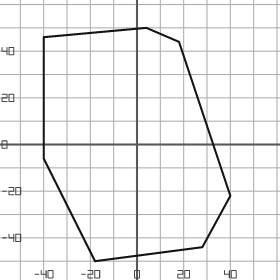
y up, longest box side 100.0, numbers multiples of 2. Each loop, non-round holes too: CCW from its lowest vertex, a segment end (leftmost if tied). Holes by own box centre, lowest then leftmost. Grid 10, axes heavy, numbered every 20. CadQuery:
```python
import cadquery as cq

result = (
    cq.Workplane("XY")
    .moveTo(-18.0, -50.0)
    .lineTo(28.0, -44.0)
    .lineTo(40.0, -22.0)
    .lineTo(18.0, 44.0)
    .lineTo(4.0, 50.0)
    .lineTo(-40.0, 46.0)
    .lineTo(-40.0, -6.0)
    .close()
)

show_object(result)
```